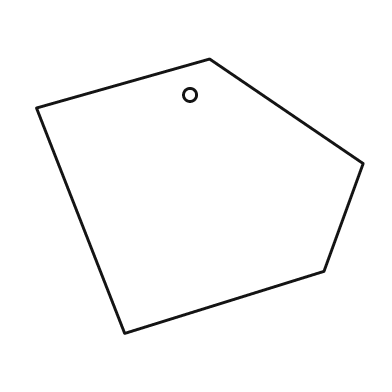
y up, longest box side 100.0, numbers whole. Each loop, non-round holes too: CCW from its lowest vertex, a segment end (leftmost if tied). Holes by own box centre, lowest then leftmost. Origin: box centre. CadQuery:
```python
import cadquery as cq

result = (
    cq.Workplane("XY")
    .moveTo(-23.0, -42.0)
    .lineTo(38.0, -23.0)
    .lineTo(50.0, 10.0)
    .lineTo(3.0, 42.0)
    .lineTo(-50.0, 27.0)
    .close()
    .moveTo(-3.0, 31.0)
    .circle(2.0)
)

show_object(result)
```